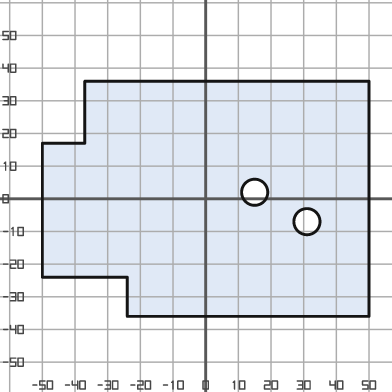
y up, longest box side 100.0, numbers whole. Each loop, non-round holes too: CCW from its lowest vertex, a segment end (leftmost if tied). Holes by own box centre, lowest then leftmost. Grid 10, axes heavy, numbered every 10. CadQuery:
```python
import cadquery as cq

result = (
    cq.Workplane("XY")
    .moveTo(-24.0, -36.0)
    .lineTo(50.0, -36.0)
    .lineTo(50.0, 36.0)
    .lineTo(-37.0, 36.0)
    .lineTo(-37.0, 17.0)
    .lineTo(-50.0, 17.0)
    .lineTo(-50.0, -24.0)
    .lineTo(-24.0, -24.0)
    .close()
    .moveTo(31.0, -7.0)
    .circle(4.0)
    .moveTo(15.0, 2.0)
    .circle(4.0)
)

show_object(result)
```